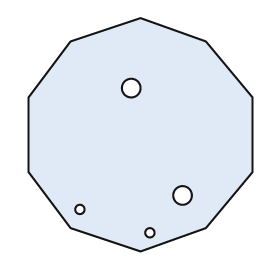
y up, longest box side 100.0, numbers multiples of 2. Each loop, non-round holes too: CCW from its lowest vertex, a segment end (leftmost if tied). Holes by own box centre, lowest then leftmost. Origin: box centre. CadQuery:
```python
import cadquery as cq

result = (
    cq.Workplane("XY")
    .moveTo(0.0, -50.0)
    .lineTo(28.0, -40.0)
    .lineTo(48.0, -16.0)
    .lineTo(48.0, 16.0)
    .lineTo(28.0, 40.0)
    .lineTo(0.0, 50.0)
    .lineTo(-30.0, 40.0)
    .lineTo(-48.0, 16.0)
    .lineTo(-48.0, -16.0)
    .lineTo(-30.0, -40.0)
    .close()
    .moveTo(4.0, -42.0)
    .circle(2.0)
    .moveTo(-26.0, -32.0)
    .circle(2.0)
    .moveTo(18.0, -26.0)
    .circle(4.0)
    .moveTo(-4.0, 20.0)
    .circle(4.0)
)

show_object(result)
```